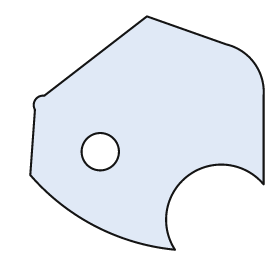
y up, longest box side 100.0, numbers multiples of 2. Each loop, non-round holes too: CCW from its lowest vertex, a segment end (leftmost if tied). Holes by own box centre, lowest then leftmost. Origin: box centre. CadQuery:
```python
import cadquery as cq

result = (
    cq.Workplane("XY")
    .moveTo(12.0, -50.0)
    .threePointArc((18.0, -18.0), (50.0, -22.0))
    .lineTo(50.0, 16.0)
    .threePointArc((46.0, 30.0), (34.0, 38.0))
    .lineTo(0.0, 50.0)
    .lineTo(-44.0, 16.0)
    .threePointArc((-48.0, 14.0), (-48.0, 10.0))
    .lineTo(-50.0, -18.0)
    .threePointArc((-22.0, -40.0), (12.0, -50.0))
    .close()
    .moveTo(-20.0, -8.0)
    .circle(8.0)
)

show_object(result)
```